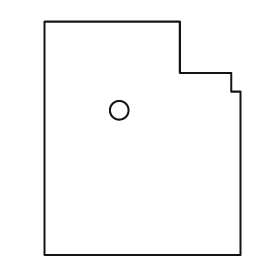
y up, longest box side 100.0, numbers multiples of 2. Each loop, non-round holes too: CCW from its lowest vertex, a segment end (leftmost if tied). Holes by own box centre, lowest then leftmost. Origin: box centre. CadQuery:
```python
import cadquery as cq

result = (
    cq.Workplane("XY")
    .moveTo(-42.0, -50.0)
    .lineTo(42.0, -50.0)
    .lineTo(42.0, 20.0)
    .lineTo(38.0, 20.0)
    .lineTo(38.0, 28.0)
    .lineTo(16.0, 28.0)
    .lineTo(16.0, 50.0)
    .lineTo(-42.0, 50.0)
    .close()
    .moveTo(-10.0, 12.0)
    .circle(4.0)
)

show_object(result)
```